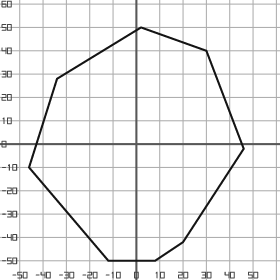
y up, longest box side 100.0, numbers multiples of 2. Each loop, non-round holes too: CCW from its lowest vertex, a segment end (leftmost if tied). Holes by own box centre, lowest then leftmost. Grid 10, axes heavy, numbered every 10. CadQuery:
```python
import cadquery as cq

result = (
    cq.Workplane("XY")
    .moveTo(-12.0, -50.0)
    .lineTo(8.0, -50.0)
    .lineTo(20.0, -42.0)
    .lineTo(46.0, -2.0)
    .lineTo(30.0, 40.0)
    .lineTo(2.0, 50.0)
    .lineTo(-34.0, 28.0)
    .lineTo(-46.0, -10.0)
    .close()
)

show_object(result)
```